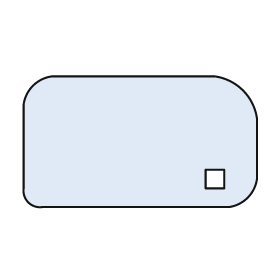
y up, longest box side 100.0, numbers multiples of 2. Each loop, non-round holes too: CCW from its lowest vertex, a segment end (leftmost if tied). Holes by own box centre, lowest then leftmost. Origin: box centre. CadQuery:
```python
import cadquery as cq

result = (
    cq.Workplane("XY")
    .moveTo(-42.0, -28.0)
    .lineTo(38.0, -28.0)
    .threePointArc((46.0, -24.0), (50.0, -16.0))
    .lineTo(50.0, 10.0)
    .threePointArc((44.0, 22.0), (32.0, 28.0))
    .lineTo(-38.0, 28.0)
    .threePointArc((-46.0, 24.0), (-50.0, 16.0))
    .lineTo(-50.0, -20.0)
    .threePointArc((-48.0, -26.0), (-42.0, -28.0))
    .close()
    .moveTo(28.0, -20.0)
    .lineTo(36.0, -20.0)
    .lineTo(36.0, -12.0)
    .lineTo(28.0, -12.0)
    .close()
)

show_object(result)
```